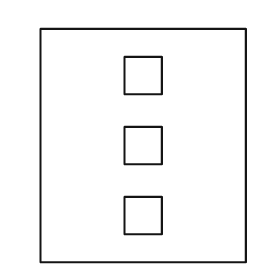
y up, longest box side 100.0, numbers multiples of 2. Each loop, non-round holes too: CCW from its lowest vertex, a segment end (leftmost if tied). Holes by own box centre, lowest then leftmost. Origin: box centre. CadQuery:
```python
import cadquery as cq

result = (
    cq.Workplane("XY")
    .moveTo(-44.0, -50.0)
    .lineTo(44.0, -50.0)
    .lineTo(44.0, 50.0)
    .lineTo(-44.0, 50.0)
    .close()
    .moveTo(-8.0, -38.0)
    .lineTo(8.0, -38.0)
    .lineTo(8.0, -22.0)
    .lineTo(-8.0, -22.0)
    .close()
    .moveTo(-8.0, -8.0)
    .lineTo(8.0, -8.0)
    .lineTo(8.0, 8.0)
    .lineTo(-8.0, 8.0)
    .close()
    .moveTo(-8.0, 22.0)
    .lineTo(8.0, 22.0)
    .lineTo(8.0, 38.0)
    .lineTo(-8.0, 38.0)
    .close()
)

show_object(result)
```